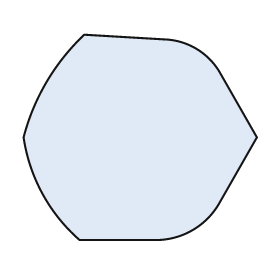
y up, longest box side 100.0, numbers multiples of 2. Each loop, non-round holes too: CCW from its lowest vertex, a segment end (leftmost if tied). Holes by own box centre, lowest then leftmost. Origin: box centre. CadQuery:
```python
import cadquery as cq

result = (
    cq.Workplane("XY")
    .moveTo(-26.0, -44.0)
    .lineTo(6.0, -44.0)
    .threePointArc((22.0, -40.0), (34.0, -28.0))
    .lineTo(50.0, 0.0)
    .lineTo(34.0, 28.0)
    .threePointArc((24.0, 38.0), (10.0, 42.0))
    .lineTo(-24.0, 44.0)
    .threePointArc((-40.0, 24.0), (-50.0, 0.0))
    .threePointArc((-42.0, -24.0), (-26.0, -44.0))
    .close()
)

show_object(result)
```